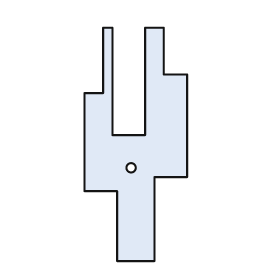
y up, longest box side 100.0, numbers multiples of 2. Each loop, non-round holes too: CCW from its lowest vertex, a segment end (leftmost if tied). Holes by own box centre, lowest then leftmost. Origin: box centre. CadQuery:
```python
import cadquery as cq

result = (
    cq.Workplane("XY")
    .moveTo(-8.0, -50.0)
    .lineTo(8.0, -50.0)
    .lineTo(8.0, -14.0)
    .lineTo(22.0, -14.0)
    .lineTo(22.0, 30.0)
    .lineTo(12.0, 30.0)
    .lineTo(12.0, 50.0)
    .lineTo(4.0, 50.0)
    .lineTo(4.0, 4.0)
    .lineTo(-10.0, 4.0)
    .lineTo(-10.0, 50.0)
    .lineTo(-14.0, 50.0)
    .lineTo(-14.0, 22.0)
    .lineTo(-22.0, 22.0)
    .lineTo(-22.0, -20.0)
    .lineTo(-8.0, -20.0)
    .close()
    .moveTo(-2.0, -10.0)
    .circle(2.0)
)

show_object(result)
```